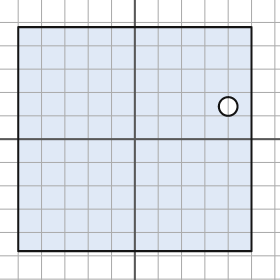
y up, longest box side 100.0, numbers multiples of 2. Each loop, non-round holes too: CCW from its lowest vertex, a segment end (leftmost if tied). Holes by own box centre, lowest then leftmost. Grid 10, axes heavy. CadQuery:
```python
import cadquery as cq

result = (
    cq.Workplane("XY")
    .moveTo(-50.0, -48.0)
    .lineTo(50.0, -48.0)
    .lineTo(50.0, 48.0)
    .lineTo(-50.0, 48.0)
    .close()
    .moveTo(40.0, 14.0)
    .circle(4.0)
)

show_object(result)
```